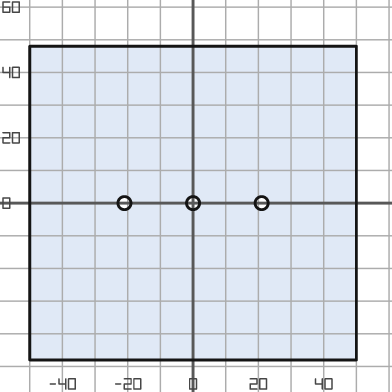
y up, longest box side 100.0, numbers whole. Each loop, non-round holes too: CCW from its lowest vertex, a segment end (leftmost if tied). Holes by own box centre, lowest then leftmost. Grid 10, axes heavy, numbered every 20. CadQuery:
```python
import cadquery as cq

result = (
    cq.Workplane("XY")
    .moveTo(-50.0, -48.0)
    .lineTo(50.0, -48.0)
    .lineTo(50.0, 48.0)
    .lineTo(-50.0, 48.0)
    .close()
    .moveTo(-21.0, 0.0)
    .circle(2.0)
    .moveTo(0.0, 0.0)
    .circle(2.0)
    .moveTo(21.0, 0.0)
    .circle(2.0)
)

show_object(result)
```